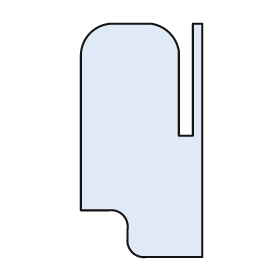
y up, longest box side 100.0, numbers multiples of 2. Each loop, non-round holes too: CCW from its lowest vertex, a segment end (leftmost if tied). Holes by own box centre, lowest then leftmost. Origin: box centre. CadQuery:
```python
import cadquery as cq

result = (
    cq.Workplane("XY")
    .moveTo(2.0, -50.0)
    .lineTo(26.0, -50.0)
    .lineTo(26.0, 50.0)
    .lineTo(22.0, 50.0)
    .lineTo(22.0, 2.0)
    .lineTo(16.0, 2.0)
    .lineTo(16.0, 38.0)
    .threePointArc((12.0, 46.0), (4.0, 50.0))
    .lineTo(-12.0, 50.0)
    .threePointArc((-22.0, 46.0), (-26.0, 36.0))
    .lineTo(-26.0, -30.0)
    .lineTo(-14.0, -30.0)
    .threePointArc((-8.0, -32.0), (-6.0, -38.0))
    .lineTo(-6.0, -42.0)
    .threePointArc((-4.0, -48.0), (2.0, -50.0))
    .close()
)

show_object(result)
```